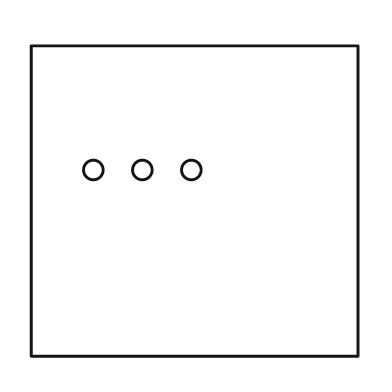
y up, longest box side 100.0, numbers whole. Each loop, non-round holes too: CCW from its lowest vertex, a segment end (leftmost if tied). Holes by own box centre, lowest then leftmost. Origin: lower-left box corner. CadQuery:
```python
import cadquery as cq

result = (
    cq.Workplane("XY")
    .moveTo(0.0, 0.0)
    .lineTo(100.0, 0.0)
    .lineTo(100.0, 95.0)
    .lineTo(0.0, 95.0)
    .close()
    .moveTo(19.0, 57.0)
    .circle(3.0)
    .moveTo(34.0, 57.0)
    .circle(3.0)
    .moveTo(49.0, 57.0)
    .circle(3.0)
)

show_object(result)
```